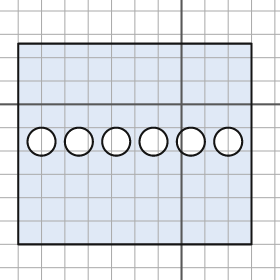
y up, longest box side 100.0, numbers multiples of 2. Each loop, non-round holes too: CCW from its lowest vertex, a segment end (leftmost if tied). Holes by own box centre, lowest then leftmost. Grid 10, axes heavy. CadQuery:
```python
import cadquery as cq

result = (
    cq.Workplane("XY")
    .moveTo(-70.0, -60.0)
    .lineTo(30.0, -60.0)
    .lineTo(30.0, 26.0)
    .lineTo(-70.0, 26.0)
    .close()
    .moveTo(-60.0, -16.0)
    .circle(6.0)
    .moveTo(-44.0, -16.0)
    .circle(6.0)
    .moveTo(-28.0, -16.0)
    .circle(6.0)
    .moveTo(-12.0, -16.0)
    .circle(6.0)
    .moveTo(4.0, -16.0)
    .circle(6.0)
    .moveTo(20.0, -16.0)
    .circle(6.0)
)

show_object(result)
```